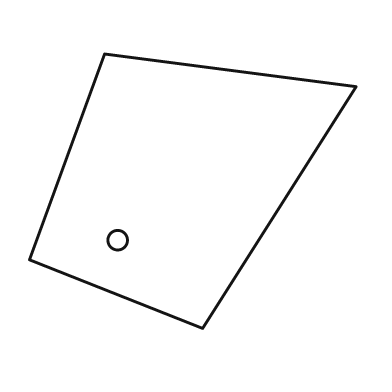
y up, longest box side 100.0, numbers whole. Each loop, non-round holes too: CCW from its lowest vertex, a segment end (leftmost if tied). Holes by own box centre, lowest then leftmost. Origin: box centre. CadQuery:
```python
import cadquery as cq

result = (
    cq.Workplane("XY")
    .moveTo(3.0, -42.0)
    .lineTo(50.0, 32.0)
    .lineTo(-27.0, 42.0)
    .lineTo(-50.0, -21.0)
    .close()
    .moveTo(-23.0, -15.0)
    .circle(3.0)
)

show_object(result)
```